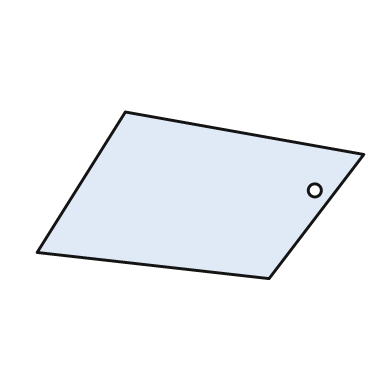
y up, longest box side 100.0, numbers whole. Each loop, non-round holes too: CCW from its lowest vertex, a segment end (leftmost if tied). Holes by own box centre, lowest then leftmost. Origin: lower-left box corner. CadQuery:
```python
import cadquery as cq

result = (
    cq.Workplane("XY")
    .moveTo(71.0, 0.0)
    .lineTo(100.0, 38.0)
    .lineTo(27.0, 51.0)
    .lineTo(0.0, 8.0)
    .close()
    .moveTo(85.0, 27.0)
    .circle(2.0)
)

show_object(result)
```